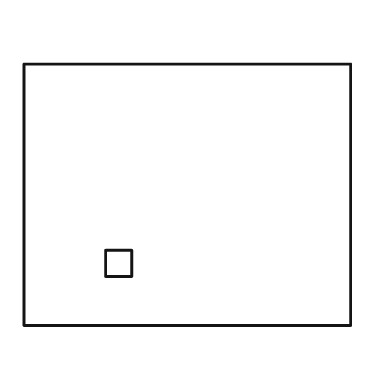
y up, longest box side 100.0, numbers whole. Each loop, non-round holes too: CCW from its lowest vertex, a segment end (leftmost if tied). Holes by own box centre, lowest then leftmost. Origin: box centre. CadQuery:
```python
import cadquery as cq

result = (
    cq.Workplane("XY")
    .moveTo(-50.0, -40.0)
    .lineTo(50.0, -40.0)
    .lineTo(50.0, 40.0)
    .lineTo(-50.0, 40.0)
    .close()
    .moveTo(-25.0, -25.0)
    .lineTo(-17.0, -25.0)
    .lineTo(-17.0, -17.0)
    .lineTo(-25.0, -17.0)
    .close()
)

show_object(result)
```